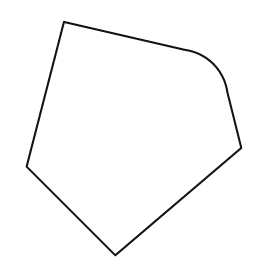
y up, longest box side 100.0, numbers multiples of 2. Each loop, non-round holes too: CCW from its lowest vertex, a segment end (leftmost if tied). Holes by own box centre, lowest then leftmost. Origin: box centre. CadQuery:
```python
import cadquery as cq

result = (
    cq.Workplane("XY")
    .moveTo(-8.0, -50.0)
    .lineTo(46.0, -4.0)
    .lineTo(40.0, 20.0)
    .threePointArc((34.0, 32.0), (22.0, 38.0))
    .lineTo(-30.0, 50.0)
    .lineTo(-46.0, -12.0)
    .close()
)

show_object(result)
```